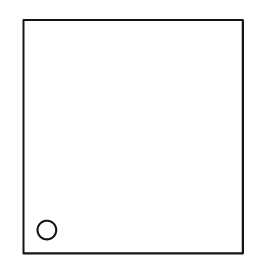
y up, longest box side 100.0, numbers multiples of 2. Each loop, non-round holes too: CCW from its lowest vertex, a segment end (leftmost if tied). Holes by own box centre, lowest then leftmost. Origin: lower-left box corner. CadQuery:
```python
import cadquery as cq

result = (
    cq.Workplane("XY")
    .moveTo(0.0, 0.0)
    .lineTo(94.0, 0.0)
    .lineTo(94.0, 100.0)
    .lineTo(0.0, 100.0)
    .close()
    .moveTo(10.0, 10.0)
    .circle(4.0)
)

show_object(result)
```